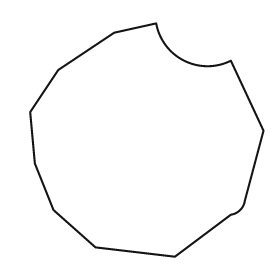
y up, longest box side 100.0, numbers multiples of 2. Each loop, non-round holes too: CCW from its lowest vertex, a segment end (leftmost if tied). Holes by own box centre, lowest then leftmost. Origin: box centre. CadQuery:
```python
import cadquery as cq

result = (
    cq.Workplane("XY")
    .moveTo(12.0, -50.0)
    .lineTo(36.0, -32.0)
    .threePointArc((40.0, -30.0), (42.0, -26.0))
    .lineTo(50.0, 4.0)
    .lineTo(36.0, 34.0)
    .threePointArc((16.0, 34.0), (4.0, 50.0))
    .lineTo(-14.0, 46.0)
    .lineTo(-38.0, 30.0)
    .lineTo(-50.0, 12.0)
    .lineTo(-48.0, -10.0)
    .lineTo(-40.0, -30.0)
    .lineTo(-22.0, -46.0)
    .close()
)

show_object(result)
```